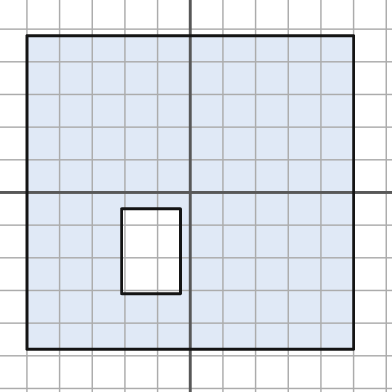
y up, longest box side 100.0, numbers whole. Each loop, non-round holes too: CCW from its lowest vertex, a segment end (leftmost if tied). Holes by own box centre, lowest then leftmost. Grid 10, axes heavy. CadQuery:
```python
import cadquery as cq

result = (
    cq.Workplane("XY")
    .moveTo(-50.0, -48.0)
    .lineTo(50.0, -48.0)
    .lineTo(50.0, 48.0)
    .lineTo(-50.0, 48.0)
    .close()
    .moveTo(-21.0, -31.0)
    .lineTo(-3.0, -31.0)
    .lineTo(-3.0, -5.0)
    .lineTo(-21.0, -5.0)
    .close()
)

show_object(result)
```